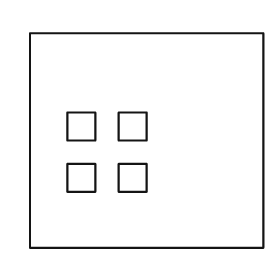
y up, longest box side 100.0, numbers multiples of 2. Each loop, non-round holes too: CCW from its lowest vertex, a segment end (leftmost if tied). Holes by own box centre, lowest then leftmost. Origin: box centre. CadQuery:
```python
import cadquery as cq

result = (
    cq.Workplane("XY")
    .moveTo(-50.0, -46.0)
    .lineTo(50.0, -46.0)
    .lineTo(50.0, 46.0)
    .lineTo(-50.0, 46.0)
    .close()
    .moveTo(-34.0, -22.0)
    .lineTo(-22.0, -22.0)
    .lineTo(-22.0, -10.0)
    .lineTo(-34.0, -10.0)
    .close()
    .moveTo(-12.0, -22.0)
    .lineTo(0.0, -22.0)
    .lineTo(0.0, -10.0)
    .lineTo(-12.0, -10.0)
    .close()
    .moveTo(-34.0, 0.0)
    .lineTo(-22.0, 0.0)
    .lineTo(-22.0, 12.0)
    .lineTo(-34.0, 12.0)
    .close()
    .moveTo(-12.0, 0.0)
    .lineTo(0.0, 0.0)
    .lineTo(0.0, 12.0)
    .lineTo(-12.0, 12.0)
    .close()
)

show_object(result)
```